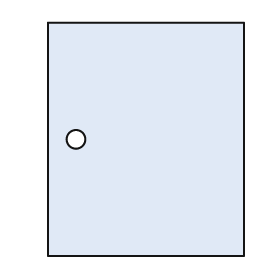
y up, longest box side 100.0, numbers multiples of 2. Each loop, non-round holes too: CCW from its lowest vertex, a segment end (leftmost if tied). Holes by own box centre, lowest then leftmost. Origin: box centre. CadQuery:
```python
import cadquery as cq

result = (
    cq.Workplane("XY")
    .moveTo(-42.0, -50.0)
    .lineTo(42.0, -50.0)
    .lineTo(42.0, 50.0)
    .lineTo(-42.0, 50.0)
    .close()
    .moveTo(-30.0, 0.0)
    .circle(4.0)
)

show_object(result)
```